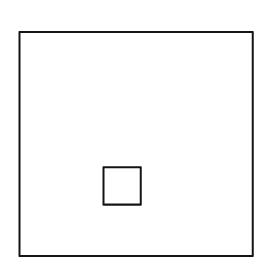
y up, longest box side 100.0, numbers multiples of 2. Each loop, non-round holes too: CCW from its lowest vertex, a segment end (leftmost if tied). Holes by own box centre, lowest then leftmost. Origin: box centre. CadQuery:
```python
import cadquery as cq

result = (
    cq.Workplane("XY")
    .moveTo(-50.0, -48.0)
    .lineTo(50.0, -48.0)
    .lineTo(50.0, 48.0)
    .lineTo(-50.0, 48.0)
    .close()
    .moveTo(-14.0, -26.0)
    .lineTo(2.0, -26.0)
    .lineTo(2.0, -10.0)
    .lineTo(-14.0, -10.0)
    .close()
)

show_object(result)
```